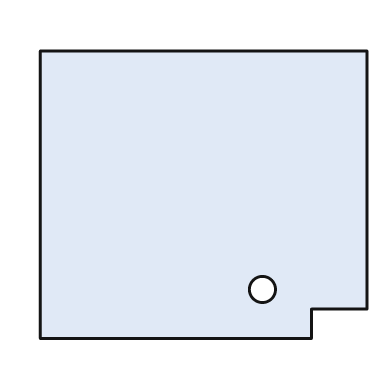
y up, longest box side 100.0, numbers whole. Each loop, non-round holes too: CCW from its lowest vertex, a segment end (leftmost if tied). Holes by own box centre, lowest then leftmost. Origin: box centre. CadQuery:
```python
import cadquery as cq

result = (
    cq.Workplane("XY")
    .moveTo(-50.0, -44.0)
    .lineTo(33.0, -44.0)
    .lineTo(33.0, -35.0)
    .lineTo(50.0, -35.0)
    .lineTo(50.0, 44.0)
    .lineTo(-50.0, 44.0)
    .close()
    .moveTo(18.0, -29.0)
    .circle(4.0)
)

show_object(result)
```